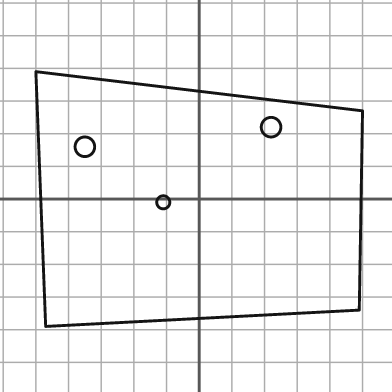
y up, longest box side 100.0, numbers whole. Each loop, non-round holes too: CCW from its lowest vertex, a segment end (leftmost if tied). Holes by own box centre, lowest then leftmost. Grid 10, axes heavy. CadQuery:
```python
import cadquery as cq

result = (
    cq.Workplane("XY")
    .moveTo(-47.0, -39.0)
    .lineTo(49.0, -34.0)
    .lineTo(50.0, 27.0)
    .lineTo(-50.0, 39.0)
    .close()
    .moveTo(-11.0, -1.0)
    .circle(2.0)
    .moveTo(-35.0, 16.0)
    .circle(3.0)
    .moveTo(22.0, 22.0)
    .circle(3.0)
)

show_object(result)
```